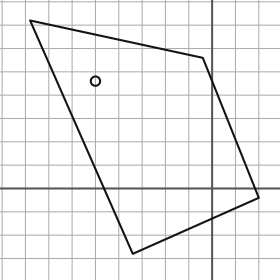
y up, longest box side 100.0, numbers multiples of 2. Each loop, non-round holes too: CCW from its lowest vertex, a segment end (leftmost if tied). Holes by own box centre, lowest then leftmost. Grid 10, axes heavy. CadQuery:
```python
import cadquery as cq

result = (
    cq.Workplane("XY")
    .moveTo(-34.0, -28.0)
    .lineTo(20.0, -4.0)
    .lineTo(-4.0, 56.0)
    .lineTo(-78.0, 72.0)
    .close()
    .moveTo(-50.0, 46.0)
    .circle(2.0)
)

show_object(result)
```